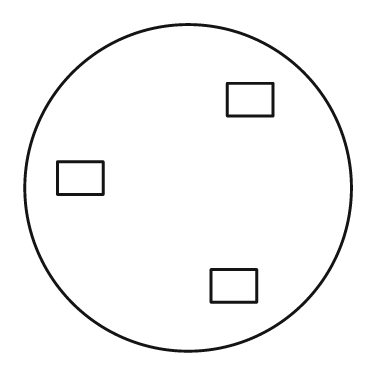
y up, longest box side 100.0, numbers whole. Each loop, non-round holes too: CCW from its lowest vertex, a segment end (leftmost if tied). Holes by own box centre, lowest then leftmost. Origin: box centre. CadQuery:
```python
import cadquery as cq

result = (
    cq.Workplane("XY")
    .moveTo(0.0, 0.0)
    .circle(50.0)
    .moveTo(7.0, -35.0)
    .lineTo(21.0, -35.0)
    .lineTo(21.0, -25.0)
    .lineTo(7.0, -25.0)
    .close()
    .moveTo(-40.0, -2.0)
    .lineTo(-26.0, -2.0)
    .lineTo(-26.0, 8.0)
    .lineTo(-40.0, 8.0)
    .close()
    .moveTo(12.0, 22.0)
    .lineTo(26.0, 22.0)
    .lineTo(26.0, 32.0)
    .lineTo(12.0, 32.0)
    .close()
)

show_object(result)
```